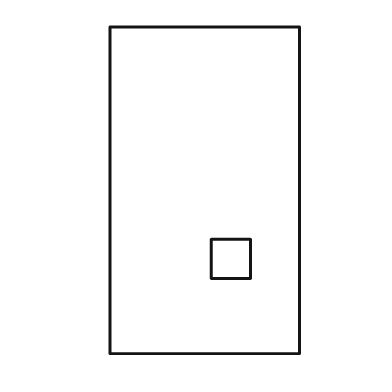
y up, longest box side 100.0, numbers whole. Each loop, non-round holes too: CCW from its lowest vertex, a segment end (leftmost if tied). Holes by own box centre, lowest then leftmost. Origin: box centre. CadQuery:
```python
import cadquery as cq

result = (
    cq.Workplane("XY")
    .moveTo(-29.0, -50.0)
    .lineTo(29.0, -50.0)
    .lineTo(29.0, 50.0)
    .lineTo(-29.0, 50.0)
    .close()
    .moveTo(2.0, -27.0)
    .lineTo(14.0, -27.0)
    .lineTo(14.0, -15.0)
    .lineTo(2.0, -15.0)
    .close()
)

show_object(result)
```